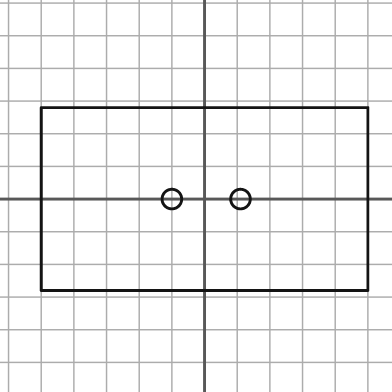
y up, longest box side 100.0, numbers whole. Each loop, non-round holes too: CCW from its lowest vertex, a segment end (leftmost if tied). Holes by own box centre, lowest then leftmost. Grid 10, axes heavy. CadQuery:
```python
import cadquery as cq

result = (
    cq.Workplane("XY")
    .moveTo(-50.0, -28.0)
    .lineTo(50.0, -28.0)
    .lineTo(50.0, 28.0)
    .lineTo(-50.0, 28.0)
    .close()
    .moveTo(-10.0, 0.0)
    .circle(3.0)
    .moveTo(11.0, 0.0)
    .circle(3.0)
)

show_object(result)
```